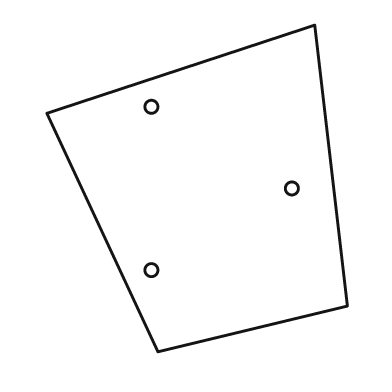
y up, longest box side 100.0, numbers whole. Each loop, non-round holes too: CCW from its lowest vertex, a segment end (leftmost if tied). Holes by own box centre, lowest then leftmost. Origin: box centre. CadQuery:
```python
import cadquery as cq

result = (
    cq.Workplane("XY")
    .moveTo(-12.0, -50.0)
    .lineTo(46.0, -36.0)
    .lineTo(36.0, 50.0)
    .lineTo(-46.0, 23.0)
    .close()
    .moveTo(-14.0, -25.0)
    .circle(2.0)
    .moveTo(29.0, 0.0)
    .circle(2.0)
    .moveTo(-14.0, 25.0)
    .circle(2.0)
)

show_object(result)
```